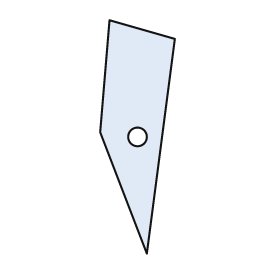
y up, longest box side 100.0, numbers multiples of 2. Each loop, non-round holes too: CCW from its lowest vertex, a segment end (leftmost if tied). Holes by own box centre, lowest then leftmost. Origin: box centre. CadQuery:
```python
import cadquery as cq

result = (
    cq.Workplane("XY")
    .moveTo(4.0, -50.0)
    .lineTo(16.0, 42.0)
    .lineTo(-12.0, 50.0)
    .lineTo(-16.0, 2.0)
    .close()
    .moveTo(0.0, 0.0)
    .circle(4.0)
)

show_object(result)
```